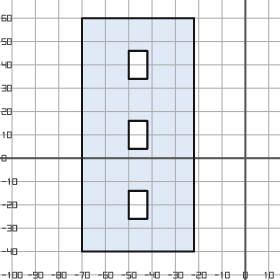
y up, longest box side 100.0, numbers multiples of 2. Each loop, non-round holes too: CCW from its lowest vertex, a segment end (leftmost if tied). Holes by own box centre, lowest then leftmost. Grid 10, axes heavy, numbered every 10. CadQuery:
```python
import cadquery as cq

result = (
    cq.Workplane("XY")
    .moveTo(-70.0, -40.0)
    .lineTo(-22.0, -40.0)
    .lineTo(-22.0, 60.0)
    .lineTo(-70.0, 60.0)
    .close()
    .moveTo(-50.0, -26.0)
    .lineTo(-42.0, -26.0)
    .lineTo(-42.0, -14.0)
    .lineTo(-50.0, -14.0)
    .close()
    .moveTo(-50.0, 4.0)
    .lineTo(-42.0, 4.0)
    .lineTo(-42.0, 16.0)
    .lineTo(-50.0, 16.0)
    .close()
    .moveTo(-50.0, 34.0)
    .lineTo(-42.0, 34.0)
    .lineTo(-42.0, 46.0)
    .lineTo(-50.0, 46.0)
    .close()
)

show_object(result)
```